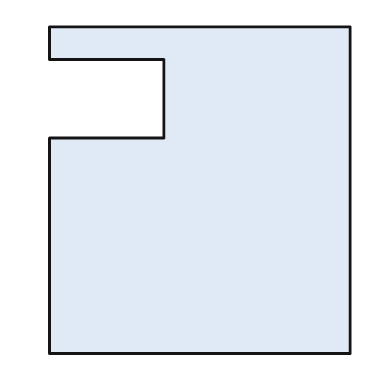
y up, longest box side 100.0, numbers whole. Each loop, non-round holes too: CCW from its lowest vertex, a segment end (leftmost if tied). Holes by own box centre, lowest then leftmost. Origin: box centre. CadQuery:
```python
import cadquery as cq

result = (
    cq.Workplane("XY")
    .moveTo(-46.0, -50.0)
    .lineTo(46.0, -50.0)
    .lineTo(46.0, 50.0)
    .lineTo(-46.0, 50.0)
    .lineTo(-46.0, 40.0)
    .lineTo(-11.0, 40.0)
    .lineTo(-11.0, 16.0)
    .lineTo(-46.0, 16.0)
    .close()
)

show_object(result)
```